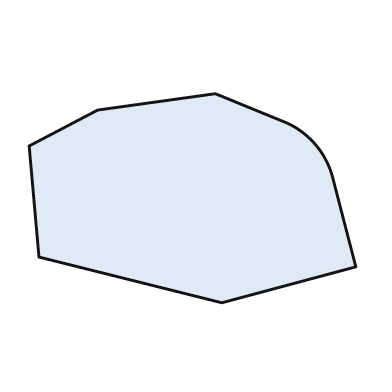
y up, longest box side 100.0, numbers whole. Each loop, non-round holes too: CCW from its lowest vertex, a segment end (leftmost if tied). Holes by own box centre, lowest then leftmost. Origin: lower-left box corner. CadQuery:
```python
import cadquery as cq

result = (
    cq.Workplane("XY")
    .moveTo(59.0, 0.0)
    .lineTo(100.0, 11.0)
    .lineTo(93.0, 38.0)
    .threePointArc((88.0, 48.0), (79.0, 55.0))
    .lineTo(57.0, 64.0)
    .lineTo(21.0, 59.0)
    .lineTo(0.0, 48.0)
    .lineTo(3.0, 14.0)
    .close()
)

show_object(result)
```